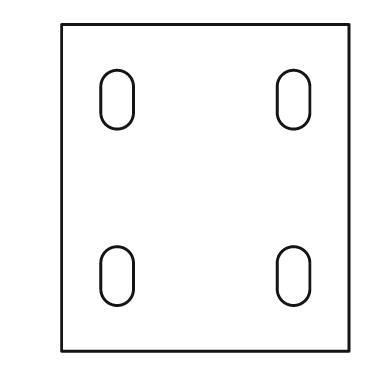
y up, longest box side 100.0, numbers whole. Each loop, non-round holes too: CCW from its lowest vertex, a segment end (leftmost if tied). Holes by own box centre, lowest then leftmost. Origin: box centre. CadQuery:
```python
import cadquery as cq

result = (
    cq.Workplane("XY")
    .moveTo(-44.0, -50.0)
    .lineTo(44.0, -50.0)
    .lineTo(44.0, 50.0)
    .lineTo(-44.0, 50.0)
    .close()
    .moveTo(-32.0, -31.0)
    .threePointArc((-27.0, -36.0), (-22.0, -31.0))
    .lineTo(-22.0, -23.0)
    .threePointArc((-27.0, -18.0), (-32.0, -23.0))
    .close()
    .moveTo(22.0, -31.0)
    .threePointArc((27.0, -36.0), (32.0, -31.0))
    .lineTo(32.0, -23.0)
    .threePointArc((27.0, -18.0), (22.0, -23.0))
    .close()
    .moveTo(-32.0, 23.0)
    .threePointArc((-27.0, 18.0), (-22.0, 23.0))
    .lineTo(-22.0, 31.0)
    .threePointArc((-27.0, 36.0), (-32.0, 31.0))
    .close()
    .moveTo(22.0, 23.0)
    .threePointArc((27.0, 18.0), (32.0, 23.0))
    .lineTo(32.0, 31.0)
    .threePointArc((27.0, 36.0), (22.0, 31.0))
    .close()
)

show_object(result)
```